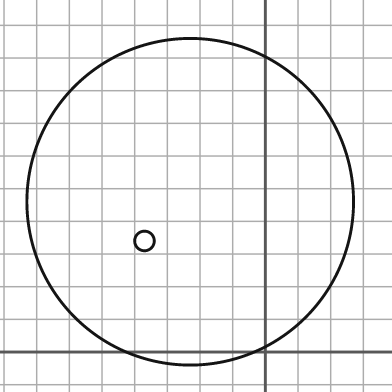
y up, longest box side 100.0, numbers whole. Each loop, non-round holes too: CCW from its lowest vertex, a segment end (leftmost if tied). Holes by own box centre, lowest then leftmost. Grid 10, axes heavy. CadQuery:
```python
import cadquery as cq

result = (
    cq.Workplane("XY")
    .moveTo(-23.0, 46.0)
    .circle(50.0)
    .moveTo(-37.0, 34.0)
    .circle(3.0)
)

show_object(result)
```